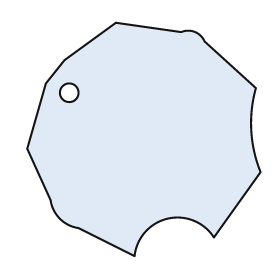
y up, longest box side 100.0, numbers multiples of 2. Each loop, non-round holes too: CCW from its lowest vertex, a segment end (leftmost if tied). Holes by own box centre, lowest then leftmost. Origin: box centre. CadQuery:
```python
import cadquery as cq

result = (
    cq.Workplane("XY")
    .moveTo(-4.0, -50.0)
    .threePointArc((10.0, -34.0), (30.0, -42.0))
    .lineTo(50.0, -14.0)
    .threePointArc((46.0, 4.0), (48.0, 22.0))
    .lineTo(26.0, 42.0)
    .threePointArc((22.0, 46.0), (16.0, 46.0))
    .lineTo(-12.0, 50.0)
    .lineTo(-34.0, 34.0)
    .lineTo(-42.0, 24.0)
    .lineTo(-50.0, -4.0)
    .lineTo(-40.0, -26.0)
    .threePointArc((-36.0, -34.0), (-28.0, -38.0))
    .close()
    .moveTo(-32.0, 20.0)
    .circle(4.0)
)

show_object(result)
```